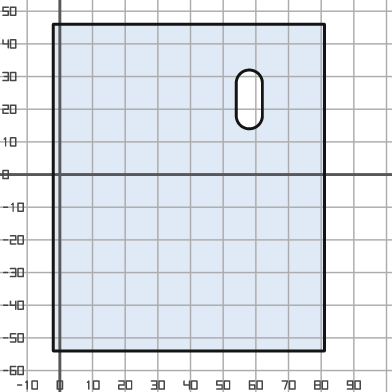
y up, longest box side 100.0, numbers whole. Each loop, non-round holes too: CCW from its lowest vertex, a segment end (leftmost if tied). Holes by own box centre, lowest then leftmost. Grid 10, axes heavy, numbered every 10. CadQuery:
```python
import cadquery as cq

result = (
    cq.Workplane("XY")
    .moveTo(-2.0, -54.0)
    .lineTo(81.0, -54.0)
    .lineTo(81.0, 46.0)
    .lineTo(-2.0, 46.0)
    .close()
    .moveTo(54.0, 18.0)
    .threePointArc((58.0, 14.0), (62.0, 18.0))
    .lineTo(62.0, 28.0)
    .threePointArc((58.0, 32.0), (54.0, 28.0))
    .close()
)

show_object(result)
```